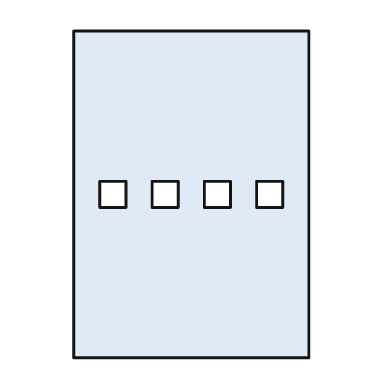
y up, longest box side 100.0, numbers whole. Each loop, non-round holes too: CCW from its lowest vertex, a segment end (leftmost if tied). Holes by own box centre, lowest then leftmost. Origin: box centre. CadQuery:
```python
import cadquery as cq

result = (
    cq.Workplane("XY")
    .moveTo(-36.0, -50.0)
    .lineTo(36.0, -50.0)
    .lineTo(36.0, 50.0)
    .lineTo(-36.0, 50.0)
    .close()
    .moveTo(-28.0, -4.0)
    .lineTo(-20.0, -4.0)
    .lineTo(-20.0, 4.0)
    .lineTo(-28.0, 4.0)
    .close()
    .moveTo(-12.0, -4.0)
    .lineTo(-4.0, -4.0)
    .lineTo(-4.0, 4.0)
    .lineTo(-12.0, 4.0)
    .close()
    .moveTo(4.0, -4.0)
    .lineTo(12.0, -4.0)
    .lineTo(12.0, 4.0)
    .lineTo(4.0, 4.0)
    .close()
    .moveTo(20.0, -4.0)
    .lineTo(28.0, -4.0)
    .lineTo(28.0, 4.0)
    .lineTo(20.0, 4.0)
    .close()
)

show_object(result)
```